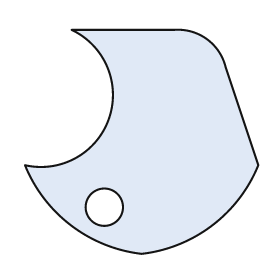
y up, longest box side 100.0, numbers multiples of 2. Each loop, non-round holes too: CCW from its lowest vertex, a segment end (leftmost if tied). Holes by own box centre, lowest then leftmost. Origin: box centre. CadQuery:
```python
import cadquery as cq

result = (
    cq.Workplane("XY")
    .moveTo(0.0, -48.0)
    .threePointArc((30.0, -36.0), (50.0, -10.0))
    .lineTo(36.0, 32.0)
    .threePointArc((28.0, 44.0), (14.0, 48.0))
    .lineTo(-30.0, 48.0)
    .threePointArc((-14.0, 10.0), (-50.0, -10.0))
    .threePointArc((-30.0, -36.0), (0.0, -48.0))
    .close()
    .moveTo(-16.0, -28.0)
    .circle(8.0)
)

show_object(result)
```